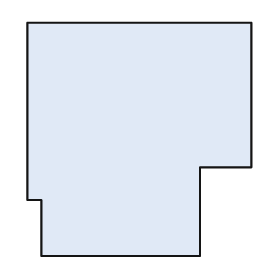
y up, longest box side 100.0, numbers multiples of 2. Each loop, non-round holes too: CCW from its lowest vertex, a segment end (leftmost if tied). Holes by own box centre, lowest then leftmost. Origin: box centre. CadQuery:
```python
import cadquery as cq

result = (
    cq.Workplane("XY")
    .moveTo(-42.0, -50.0)
    .lineTo(26.0, -50.0)
    .lineTo(26.0, -12.0)
    .lineTo(48.0, -12.0)
    .lineTo(48.0, 50.0)
    .lineTo(-48.0, 50.0)
    .lineTo(-48.0, -26.0)
    .lineTo(-42.0, -26.0)
    .close()
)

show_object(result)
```